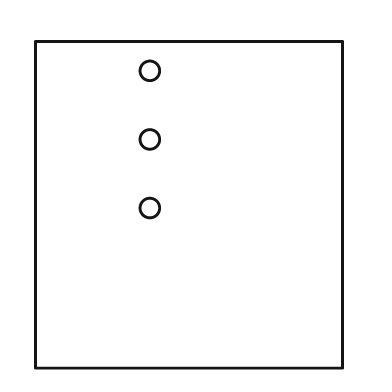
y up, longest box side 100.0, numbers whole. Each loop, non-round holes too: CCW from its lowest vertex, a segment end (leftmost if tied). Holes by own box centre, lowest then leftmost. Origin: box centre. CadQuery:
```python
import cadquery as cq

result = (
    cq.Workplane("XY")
    .moveTo(-47.0, -50.0)
    .lineTo(47.0, -50.0)
    .lineTo(47.0, 50.0)
    .lineTo(-47.0, 50.0)
    .close()
    .moveTo(-12.0, -1.0)
    .circle(3.0)
    .moveTo(-12.0, 20.0)
    .circle(3.0)
    .moveTo(-12.0, 41.0)
    .circle(3.0)
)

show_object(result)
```